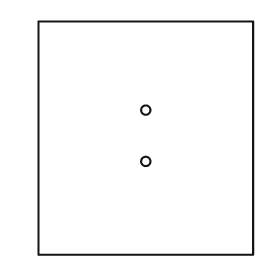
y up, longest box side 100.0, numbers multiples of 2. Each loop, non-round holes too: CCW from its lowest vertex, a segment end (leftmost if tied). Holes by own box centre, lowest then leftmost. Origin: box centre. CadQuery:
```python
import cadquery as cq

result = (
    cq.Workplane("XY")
    .moveTo(-46.0, -50.0)
    .lineTo(46.0, -50.0)
    .lineTo(46.0, 50.0)
    .lineTo(-46.0, 50.0)
    .close()
    .moveTo(0.0, -10.0)
    .circle(2.0)
    .moveTo(0.0, 12.0)
    .circle(2.0)
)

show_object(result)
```